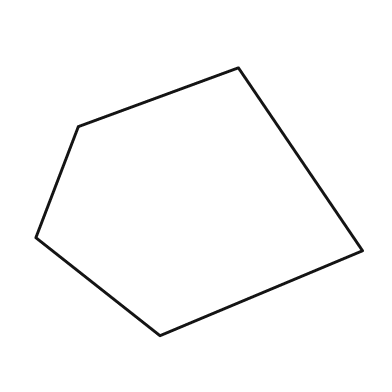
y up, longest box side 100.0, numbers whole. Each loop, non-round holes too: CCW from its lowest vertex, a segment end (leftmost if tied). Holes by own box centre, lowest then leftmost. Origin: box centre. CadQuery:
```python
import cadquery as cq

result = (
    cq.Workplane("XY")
    .moveTo(-12.0, -41.0)
    .lineTo(50.0, -15.0)
    .lineTo(12.0, 41.0)
    .lineTo(-37.0, 23.0)
    .lineTo(-50.0, -11.0)
    .close()
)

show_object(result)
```